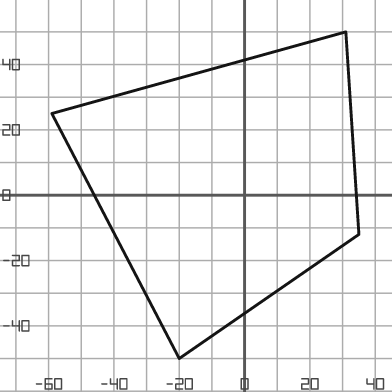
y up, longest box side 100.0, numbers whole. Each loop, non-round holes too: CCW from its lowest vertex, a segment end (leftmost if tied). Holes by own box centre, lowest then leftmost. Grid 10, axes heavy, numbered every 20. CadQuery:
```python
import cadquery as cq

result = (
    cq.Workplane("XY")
    .moveTo(-20.0, -50.0)
    .lineTo(35.0, -12.0)
    .lineTo(31.0, 50.0)
    .lineTo(-59.0, 25.0)
    .close()
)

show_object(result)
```